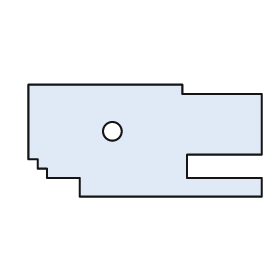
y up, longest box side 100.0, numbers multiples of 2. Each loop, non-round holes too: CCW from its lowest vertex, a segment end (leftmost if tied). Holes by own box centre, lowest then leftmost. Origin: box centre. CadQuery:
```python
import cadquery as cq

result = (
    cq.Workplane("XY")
    .moveTo(-28.0, -24.0)
    .lineTo(50.0, -24.0)
    .lineTo(50.0, -16.0)
    .lineTo(18.0, -16.0)
    .lineTo(18.0, -6.0)
    .lineTo(50.0, -6.0)
    .lineTo(50.0, 20.0)
    .lineTo(16.0, 20.0)
    .lineTo(16.0, 24.0)
    .lineTo(-50.0, 24.0)
    .lineTo(-50.0, -8.0)
    .lineTo(-46.0, -8.0)
    .lineTo(-46.0, -12.0)
    .lineTo(-42.0, -12.0)
    .lineTo(-42.0, -16.0)
    .lineTo(-28.0, -16.0)
    .close()
    .moveTo(-14.0, 4.0)
    .circle(4.0)
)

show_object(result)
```